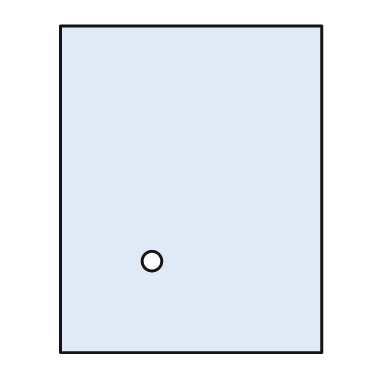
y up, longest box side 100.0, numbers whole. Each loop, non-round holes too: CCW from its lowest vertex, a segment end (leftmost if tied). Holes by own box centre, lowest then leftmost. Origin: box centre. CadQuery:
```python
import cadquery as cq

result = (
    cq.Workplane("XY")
    .moveTo(-40.0, -50.0)
    .lineTo(40.0, -50.0)
    .lineTo(40.0, 50.0)
    .lineTo(-40.0, 50.0)
    .close()
    .moveTo(-12.0, -22.0)
    .circle(3.0)
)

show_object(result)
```